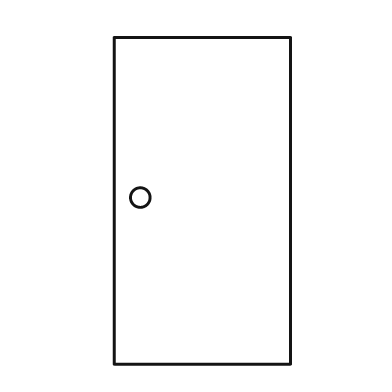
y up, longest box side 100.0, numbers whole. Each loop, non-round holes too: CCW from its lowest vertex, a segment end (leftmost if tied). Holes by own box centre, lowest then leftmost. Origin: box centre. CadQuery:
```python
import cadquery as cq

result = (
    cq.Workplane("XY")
    .moveTo(-27.0, -50.0)
    .lineTo(27.0, -50.0)
    .lineTo(27.0, 50.0)
    .lineTo(-27.0, 50.0)
    .close()
    .moveTo(-19.0, 1.0)
    .circle(3.0)
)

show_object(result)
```